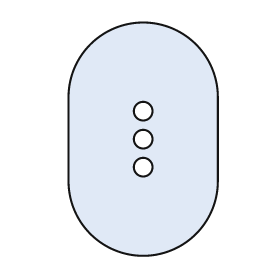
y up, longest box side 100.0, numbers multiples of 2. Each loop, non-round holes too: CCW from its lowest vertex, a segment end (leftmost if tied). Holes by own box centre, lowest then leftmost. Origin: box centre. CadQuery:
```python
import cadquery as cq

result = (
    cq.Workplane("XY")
    .moveTo(-32.0, -18.0)
    .threePointArc((0.0, -50.0), (32.0, -18.0))
    .lineTo(32.0, 18.0)
    .threePointArc((0.0, 50.0), (-32.0, 18.0))
    .close()
    .moveTo(0.0, -12.0)
    .circle(4.0)
    .moveTo(0.0, 0.0)
    .circle(4.0)
    .moveTo(0.0, 12.0)
    .circle(4.0)
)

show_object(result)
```